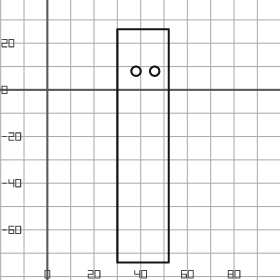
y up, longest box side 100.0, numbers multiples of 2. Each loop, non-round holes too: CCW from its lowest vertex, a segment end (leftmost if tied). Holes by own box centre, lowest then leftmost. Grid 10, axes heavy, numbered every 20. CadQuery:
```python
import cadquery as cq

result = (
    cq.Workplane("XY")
    .moveTo(30.0, -74.0)
    .lineTo(52.0, -74.0)
    .lineTo(52.0, 26.0)
    .lineTo(30.0, 26.0)
    .close()
    .moveTo(38.0, 8.0)
    .circle(2.0)
    .moveTo(46.0, 8.0)
    .circle(2.0)
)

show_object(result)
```